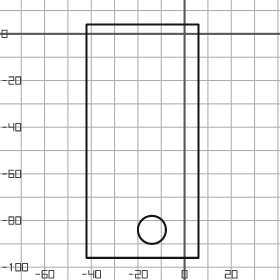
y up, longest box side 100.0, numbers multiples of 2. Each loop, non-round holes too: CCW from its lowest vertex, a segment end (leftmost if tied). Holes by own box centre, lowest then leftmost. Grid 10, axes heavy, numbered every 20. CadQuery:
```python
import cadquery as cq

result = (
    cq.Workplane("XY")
    .moveTo(-42.0, -96.0)
    .lineTo(6.0, -96.0)
    .lineTo(6.0, 4.0)
    .lineTo(-42.0, 4.0)
    .close()
    .moveTo(-14.0, -84.0)
    .circle(6.0)
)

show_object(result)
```